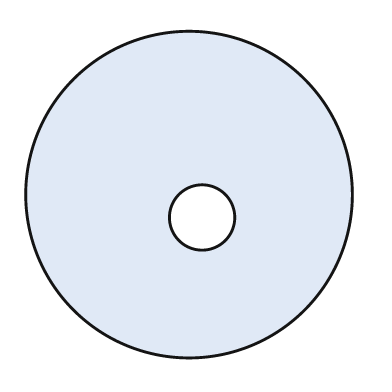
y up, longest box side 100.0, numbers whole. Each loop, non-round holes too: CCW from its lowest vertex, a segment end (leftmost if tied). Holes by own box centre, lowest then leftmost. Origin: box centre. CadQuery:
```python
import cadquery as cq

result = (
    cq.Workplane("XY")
    .moveTo(0.0, 0.0)
    .circle(50.0)
    .moveTo(4.0, -7.0)
    .circle(10.0)
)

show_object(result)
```